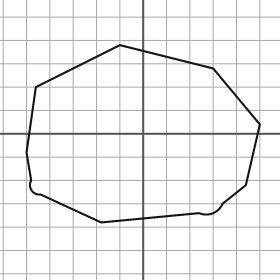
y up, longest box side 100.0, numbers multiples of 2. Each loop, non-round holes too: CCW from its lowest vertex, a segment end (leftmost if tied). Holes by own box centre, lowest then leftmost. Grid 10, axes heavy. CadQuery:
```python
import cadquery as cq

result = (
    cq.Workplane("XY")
    .moveTo(-18.0, -38.0)
    .lineTo(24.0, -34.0)
    .threePointArc((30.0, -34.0), (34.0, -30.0))
    .lineTo(44.0, -22.0)
    .lineTo(50.0, 4.0)
    .lineTo(30.0, 28.0)
    .lineTo(-10.0, 38.0)
    .lineTo(-46.0, 20.0)
    .lineTo(-50.0, -8.0)
    .lineTo(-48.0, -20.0)
    .threePointArc((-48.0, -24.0), (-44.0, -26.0))
    .close()
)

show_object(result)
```